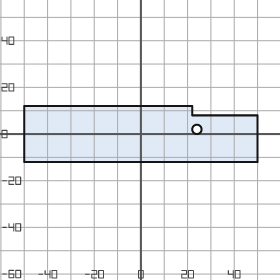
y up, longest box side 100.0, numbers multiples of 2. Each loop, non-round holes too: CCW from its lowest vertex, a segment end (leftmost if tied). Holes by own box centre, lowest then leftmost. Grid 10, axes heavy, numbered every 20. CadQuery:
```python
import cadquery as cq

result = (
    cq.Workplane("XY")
    .moveTo(-50.0, -12.0)
    .lineTo(50.0, -12.0)
    .lineTo(50.0, 8.0)
    .lineTo(22.0, 8.0)
    .lineTo(22.0, 12.0)
    .lineTo(-50.0, 12.0)
    .close()
    .moveTo(24.0, 2.0)
    .circle(2.0)
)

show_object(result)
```